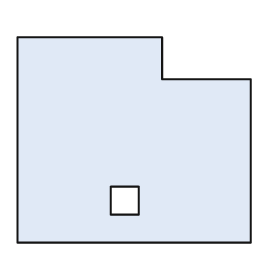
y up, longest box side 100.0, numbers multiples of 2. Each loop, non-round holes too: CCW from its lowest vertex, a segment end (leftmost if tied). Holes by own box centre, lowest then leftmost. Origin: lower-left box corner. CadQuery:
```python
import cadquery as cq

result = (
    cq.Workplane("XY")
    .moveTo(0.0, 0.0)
    .lineTo(100.0, 0.0)
    .lineTo(100.0, 70.0)
    .lineTo(62.0, 70.0)
    .lineTo(62.0, 88.0)
    .lineTo(0.0, 88.0)
    .close()
    .moveTo(40.0, 12.0)
    .lineTo(52.0, 12.0)
    .lineTo(52.0, 24.0)
    .lineTo(40.0, 24.0)
    .close()
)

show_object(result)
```